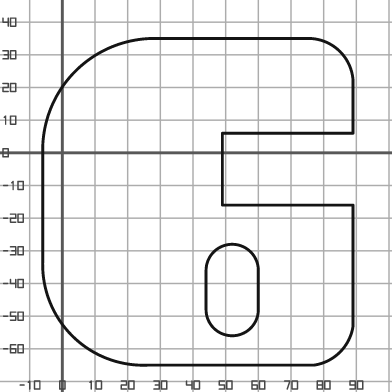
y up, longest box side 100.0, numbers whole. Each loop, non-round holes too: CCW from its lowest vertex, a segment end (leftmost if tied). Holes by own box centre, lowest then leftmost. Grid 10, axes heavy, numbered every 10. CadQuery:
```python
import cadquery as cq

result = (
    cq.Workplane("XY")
    .moveTo(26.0, -65.0)
    .lineTo(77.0, -65.0)
    .threePointArc((85.0, -61.0), (89.0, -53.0))
    .lineTo(89.0, -16.0)
    .lineTo(49.0, -16.0)
    .lineTo(49.0, 6.0)
    .lineTo(89.0, 6.0)
    .lineTo(89.0, 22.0)
    .threePointArc((85.0, 31.0), (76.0, 35.0))
    .lineTo(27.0, 35.0)
    .threePointArc((4.0, 25.0), (-6.0, 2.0))
    .lineTo(-6.0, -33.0)
    .threePointArc((3.0, -56.0), (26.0, -65.0))
    .close()
    .moveTo(44.0, -48.0)
    .threePointArc((52.0, -56.0), (60.0, -48.0))
    .lineTo(60.0, -36.0)
    .threePointArc((52.0, -28.0), (44.0, -36.0))
    .close()
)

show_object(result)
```